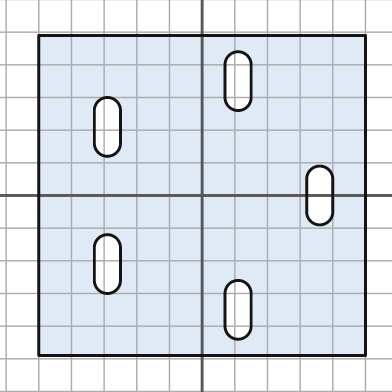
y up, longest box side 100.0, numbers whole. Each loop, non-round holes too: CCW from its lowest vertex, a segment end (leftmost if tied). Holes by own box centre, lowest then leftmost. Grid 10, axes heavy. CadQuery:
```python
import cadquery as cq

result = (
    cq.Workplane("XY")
    .moveTo(-50.0, -49.0)
    .lineTo(50.0, -49.0)
    .lineTo(50.0, 49.0)
    .lineTo(-50.0, 49.0)
    .close()
    .moveTo(7.0, -40.0)
    .threePointArc((11.0, -44.0), (15.0, -40.0))
    .lineTo(15.0, -30.0)
    .threePointArc((11.0, -26.0), (7.0, -30.0))
    .close()
    .moveTo(-33.0, -26.0)
    .threePointArc((-29.0, -30.0), (-25.0, -26.0))
    .lineTo(-25.0, -16.0)
    .threePointArc((-29.0, -12.0), (-33.0, -16.0))
    .close()
    .moveTo(32.0, -5.0)
    .threePointArc((36.0, -9.0), (40.0, -5.0))
    .lineTo(40.0, 5.0)
    .threePointArc((36.0, 9.0), (32.0, 5.0))
    .close()
    .moveTo(-33.0, 16.0)
    .threePointArc((-29.0, 12.0), (-25.0, 16.0))
    .lineTo(-25.0, 26.0)
    .threePointArc((-29.0, 30.0), (-33.0, 26.0))
    .close()
    .moveTo(7.0, 30.0)
    .threePointArc((11.0, 26.0), (15.0, 30.0))
    .lineTo(15.0, 40.0)
    .threePointArc((11.0, 44.0), (7.0, 40.0))
    .close()
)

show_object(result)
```